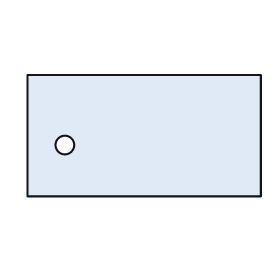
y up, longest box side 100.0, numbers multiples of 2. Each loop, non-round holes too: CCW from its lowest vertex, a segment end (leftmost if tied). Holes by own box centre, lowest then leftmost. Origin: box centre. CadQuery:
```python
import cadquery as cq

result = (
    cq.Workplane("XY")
    .moveTo(-50.0, -26.0)
    .lineTo(50.0, -26.0)
    .lineTo(50.0, 26.0)
    .lineTo(-50.0, 26.0)
    .close()
    .moveTo(-34.0, -4.0)
    .circle(4.0)
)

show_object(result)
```